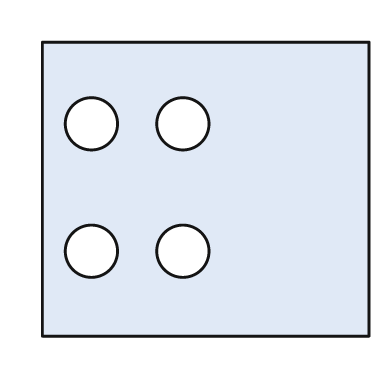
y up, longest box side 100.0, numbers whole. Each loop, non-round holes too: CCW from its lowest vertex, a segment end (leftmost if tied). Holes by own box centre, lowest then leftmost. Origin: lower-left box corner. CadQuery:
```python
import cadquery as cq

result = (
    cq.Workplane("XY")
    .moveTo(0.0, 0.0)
    .lineTo(100.0, 0.0)
    .lineTo(100.0, 90.0)
    .lineTo(0.0, 90.0)
    .close()
    .moveTo(15.0, 26.0)
    .circle(8.0)
    .moveTo(43.0, 26.0)
    .circle(8.0)
    .moveTo(15.0, 65.0)
    .circle(8.0)
    .moveTo(43.0, 65.0)
    .circle(8.0)
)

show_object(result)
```